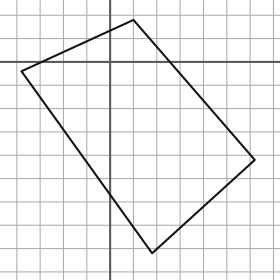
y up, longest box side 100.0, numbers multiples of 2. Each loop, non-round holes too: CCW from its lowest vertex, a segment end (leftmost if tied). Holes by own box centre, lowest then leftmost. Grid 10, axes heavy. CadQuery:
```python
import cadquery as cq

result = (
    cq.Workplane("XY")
    .moveTo(18.0, -82.0)
    .lineTo(62.0, -42.0)
    .lineTo(10.0, 18.0)
    .lineTo(-38.0, -4.0)
    .close()
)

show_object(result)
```